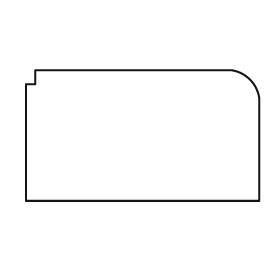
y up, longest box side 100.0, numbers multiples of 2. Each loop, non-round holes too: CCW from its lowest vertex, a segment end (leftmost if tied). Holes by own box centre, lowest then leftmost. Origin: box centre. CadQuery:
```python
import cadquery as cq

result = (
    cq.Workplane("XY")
    .moveTo(-50.0, -28.0)
    .lineTo(50.0, -28.0)
    .lineTo(50.0, 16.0)
    .threePointArc((46.0, 24.0), (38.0, 28.0))
    .lineTo(-46.0, 28.0)
    .lineTo(-46.0, 22.0)
    .lineTo(-50.0, 22.0)
    .close()
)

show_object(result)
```